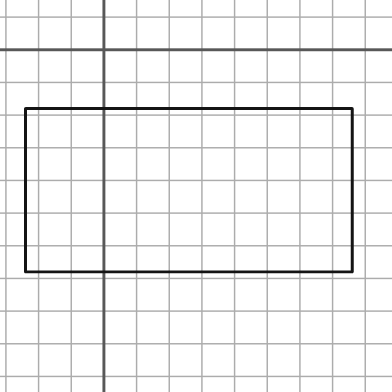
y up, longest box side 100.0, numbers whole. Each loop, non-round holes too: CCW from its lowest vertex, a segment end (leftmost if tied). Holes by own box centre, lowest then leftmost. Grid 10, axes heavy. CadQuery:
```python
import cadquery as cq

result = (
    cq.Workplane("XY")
    .moveTo(-24.0, -68.0)
    .lineTo(76.0, -68.0)
    .lineTo(76.0, -18.0)
    .lineTo(-24.0, -18.0)
    .close()
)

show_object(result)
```